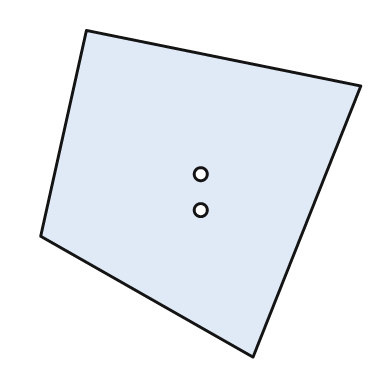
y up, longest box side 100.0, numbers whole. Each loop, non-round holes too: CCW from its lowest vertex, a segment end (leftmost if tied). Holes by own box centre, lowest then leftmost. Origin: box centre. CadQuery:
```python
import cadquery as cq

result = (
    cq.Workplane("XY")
    .moveTo(16.0, -50.0)
    .lineTo(49.0, 33.0)
    .lineTo(-35.0, 50.0)
    .lineTo(-49.0, -13.0)
    .close()
    .moveTo(0.0, -5.0)
    .circle(2.0)
    .moveTo(0.0, 6.0)
    .circle(2.0)
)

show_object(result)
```